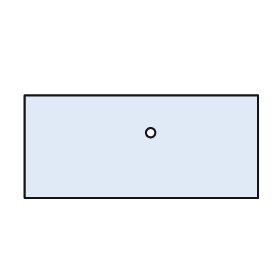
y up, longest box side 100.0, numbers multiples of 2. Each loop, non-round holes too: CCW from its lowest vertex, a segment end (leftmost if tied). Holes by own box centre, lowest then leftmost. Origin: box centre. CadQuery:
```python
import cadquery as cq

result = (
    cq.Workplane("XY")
    .moveTo(-50.0, -22.0)
    .lineTo(50.0, -22.0)
    .lineTo(50.0, 22.0)
    .lineTo(-50.0, 22.0)
    .close()
    .moveTo(4.0, 6.0)
    .circle(2.0)
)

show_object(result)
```